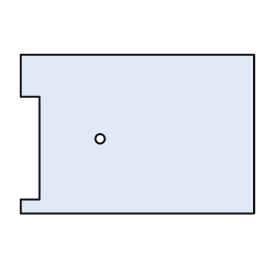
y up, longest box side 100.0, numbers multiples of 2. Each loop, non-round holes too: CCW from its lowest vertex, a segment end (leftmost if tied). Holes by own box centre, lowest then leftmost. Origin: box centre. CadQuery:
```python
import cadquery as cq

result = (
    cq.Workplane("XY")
    .moveTo(-50.0, -34.0)
    .lineTo(50.0, -34.0)
    .lineTo(50.0, 34.0)
    .lineTo(-50.0, 34.0)
    .lineTo(-50.0, 16.0)
    .lineTo(-42.0, 16.0)
    .lineTo(-42.0, -28.0)
    .lineTo(-50.0, -28.0)
    .close()
    .moveTo(-16.0, -2.0)
    .circle(2.0)
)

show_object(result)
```